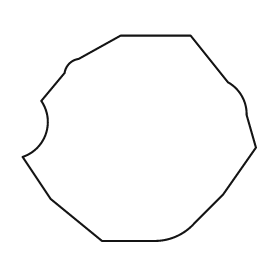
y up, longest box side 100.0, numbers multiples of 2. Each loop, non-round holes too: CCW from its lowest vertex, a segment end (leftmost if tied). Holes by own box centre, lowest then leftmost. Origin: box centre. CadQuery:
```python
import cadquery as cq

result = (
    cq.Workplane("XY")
    .moveTo(-16.0, -44.0)
    .lineTo(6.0, -44.0)
    .threePointArc((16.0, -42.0), (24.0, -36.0))
    .lineTo(36.0, -24.0)
    .lineTo(50.0, -4.0)
    .lineTo(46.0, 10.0)
    .threePointArc((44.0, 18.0), (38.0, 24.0))
    .lineTo(22.0, 44.0)
    .lineTo(-8.0, 44.0)
    .lineTo(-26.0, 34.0)
    .threePointArc((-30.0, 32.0), (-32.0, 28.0))
    .lineTo(-42.0, 16.0)
    .threePointArc((-40.0, 2.0), (-50.0, -8.0))
    .lineTo(-38.0, -26.0)
    .close()
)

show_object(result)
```